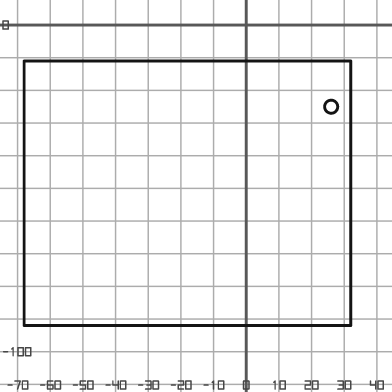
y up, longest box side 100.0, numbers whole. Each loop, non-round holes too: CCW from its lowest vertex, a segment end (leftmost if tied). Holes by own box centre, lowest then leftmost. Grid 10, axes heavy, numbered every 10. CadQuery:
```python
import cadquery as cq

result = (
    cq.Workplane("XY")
    .moveTo(-68.0, -92.0)
    .lineTo(32.0, -92.0)
    .lineTo(32.0, -11.0)
    .lineTo(-68.0, -11.0)
    .close()
    .moveTo(26.0, -25.0)
    .circle(2.0)
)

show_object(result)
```